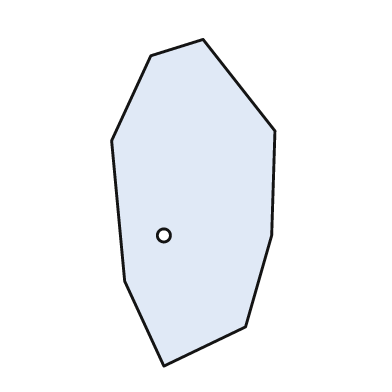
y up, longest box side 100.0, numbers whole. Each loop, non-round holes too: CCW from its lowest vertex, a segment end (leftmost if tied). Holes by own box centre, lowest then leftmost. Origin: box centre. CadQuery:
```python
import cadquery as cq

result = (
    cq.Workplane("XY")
    .moveTo(-9.0, -50.0)
    .lineTo(16.0, -38.0)
    .lineTo(24.0, -10.0)
    .lineTo(25.0, 22.0)
    .lineTo(3.0, 50.0)
    .lineTo(-13.0, 45.0)
    .lineTo(-25.0, 19.0)
    .lineTo(-21.0, -24.0)
    .close()
    .moveTo(-9.0, -10.0)
    .circle(2.0)
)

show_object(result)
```